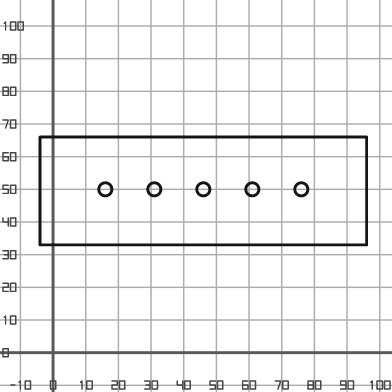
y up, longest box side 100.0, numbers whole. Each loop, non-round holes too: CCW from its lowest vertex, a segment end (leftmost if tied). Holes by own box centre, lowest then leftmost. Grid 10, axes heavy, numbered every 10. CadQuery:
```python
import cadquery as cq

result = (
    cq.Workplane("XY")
    .moveTo(-4.0, 33.0)
    .lineTo(96.0, 33.0)
    .lineTo(96.0, 66.0)
    .lineTo(-4.0, 66.0)
    .close()
    .moveTo(16.0, 50.0)
    .circle(2.0)
    .moveTo(31.0, 50.0)
    .circle(2.0)
    .moveTo(46.0, 50.0)
    .circle(2.0)
    .moveTo(61.0, 50.0)
    .circle(2.0)
    .moveTo(76.0, 50.0)
    .circle(2.0)
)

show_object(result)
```